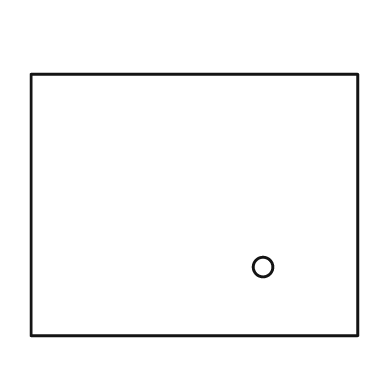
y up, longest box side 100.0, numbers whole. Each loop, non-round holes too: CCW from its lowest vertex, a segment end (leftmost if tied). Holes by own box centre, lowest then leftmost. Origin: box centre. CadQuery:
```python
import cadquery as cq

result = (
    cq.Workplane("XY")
    .moveTo(-50.0, -40.0)
    .lineTo(50.0, -40.0)
    .lineTo(50.0, 40.0)
    .lineTo(-50.0, 40.0)
    .close()
    .moveTo(21.0, -19.0)
    .circle(3.0)
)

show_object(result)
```